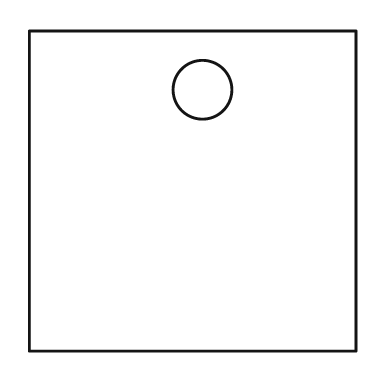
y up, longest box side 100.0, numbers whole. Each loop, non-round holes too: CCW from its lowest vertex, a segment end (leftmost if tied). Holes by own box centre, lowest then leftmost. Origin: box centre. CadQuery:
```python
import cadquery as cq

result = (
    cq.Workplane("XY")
    .moveTo(-50.0, -49.0)
    .lineTo(50.0, -49.0)
    .lineTo(50.0, 49.0)
    .lineTo(-50.0, 49.0)
    .close()
    .moveTo(3.0, 31.0)
    .circle(9.0)
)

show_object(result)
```